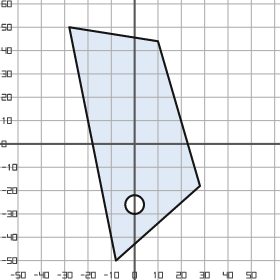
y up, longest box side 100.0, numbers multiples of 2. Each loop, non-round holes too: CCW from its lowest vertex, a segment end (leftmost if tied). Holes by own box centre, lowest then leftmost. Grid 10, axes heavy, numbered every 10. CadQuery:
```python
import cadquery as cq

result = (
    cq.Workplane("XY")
    .moveTo(-8.0, -50.0)
    .lineTo(28.0, -18.0)
    .lineTo(10.0, 44.0)
    .lineTo(-28.0, 50.0)
    .close()
    .moveTo(0.0, -26.0)
    .circle(4.0)
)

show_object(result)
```